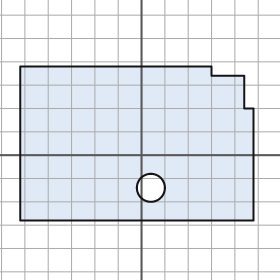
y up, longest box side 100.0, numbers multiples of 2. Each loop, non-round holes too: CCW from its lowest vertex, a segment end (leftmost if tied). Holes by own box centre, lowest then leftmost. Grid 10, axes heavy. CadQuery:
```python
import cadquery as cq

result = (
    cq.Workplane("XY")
    .moveTo(-52.0, -28.0)
    .lineTo(48.0, -28.0)
    .lineTo(48.0, 20.0)
    .lineTo(44.0, 20.0)
    .lineTo(44.0, 34.0)
    .lineTo(30.0, 34.0)
    .lineTo(30.0, 38.0)
    .lineTo(-52.0, 38.0)
    .close()
    .moveTo(4.0, -14.0)
    .circle(6.0)
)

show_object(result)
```